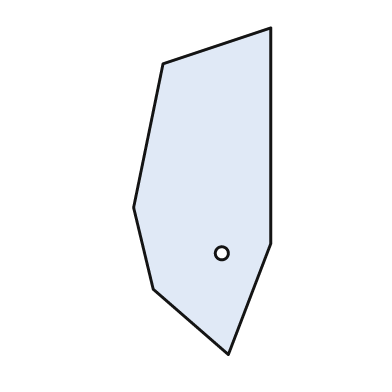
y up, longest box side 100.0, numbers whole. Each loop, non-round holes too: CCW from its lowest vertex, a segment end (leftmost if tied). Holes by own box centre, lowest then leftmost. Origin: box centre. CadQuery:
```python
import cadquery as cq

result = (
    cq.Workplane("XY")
    .moveTo(8.0, -50.0)
    .lineTo(21.0, -16.0)
    .lineTo(21.0, 50.0)
    .lineTo(-12.0, 39.0)
    .lineTo(-21.0, -5.0)
    .lineTo(-15.0, -30.0)
    .close()
    .moveTo(6.0, -19.0)
    .circle(2.0)
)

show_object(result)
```